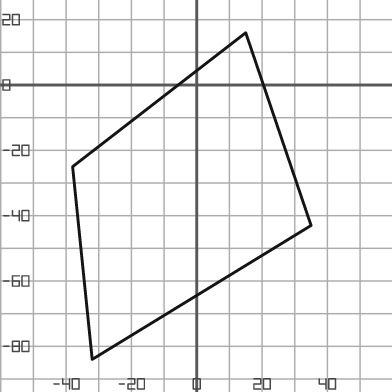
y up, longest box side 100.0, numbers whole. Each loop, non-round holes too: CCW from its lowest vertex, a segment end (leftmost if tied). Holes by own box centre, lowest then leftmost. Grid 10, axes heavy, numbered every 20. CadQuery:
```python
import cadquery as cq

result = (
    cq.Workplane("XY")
    .moveTo(-32.0, -84.0)
    .lineTo(35.0, -43.0)
    .lineTo(15.0, 16.0)
    .lineTo(-38.0, -25.0)
    .close()
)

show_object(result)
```